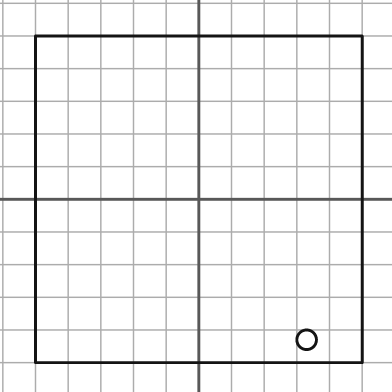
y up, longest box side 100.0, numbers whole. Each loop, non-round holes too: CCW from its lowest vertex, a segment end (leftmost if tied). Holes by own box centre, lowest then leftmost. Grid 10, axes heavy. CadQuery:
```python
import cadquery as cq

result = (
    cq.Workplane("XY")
    .moveTo(-50.0, -50.0)
    .lineTo(50.0, -50.0)
    .lineTo(50.0, 50.0)
    .lineTo(-50.0, 50.0)
    .close()
    .moveTo(33.0, -43.0)
    .circle(3.0)
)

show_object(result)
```